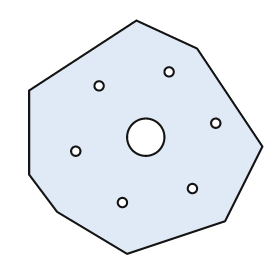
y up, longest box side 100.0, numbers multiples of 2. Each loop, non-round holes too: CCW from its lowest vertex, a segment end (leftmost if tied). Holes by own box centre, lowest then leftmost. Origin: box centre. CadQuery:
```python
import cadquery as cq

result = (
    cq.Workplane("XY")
    .moveTo(-8.0, -50.0)
    .lineTo(34.0, -36.0)
    .lineTo(50.0, -4.0)
    .lineTo(22.0, 38.0)
    .lineTo(-4.0, 50.0)
    .lineTo(-50.0, 20.0)
    .lineTo(-50.0, -16.0)
    .lineTo(-38.0, -32.0)
    .close()
    .moveTo(-10.0, -28.0)
    .circle(2.0)
    .moveTo(20.0, -22.0)
    .circle(2.0)
    .moveTo(-30.0, -6.0)
    .circle(2.0)
    .moveTo(0.0, 0.0)
    .circle(8.0)
    .moveTo(30.0, 6.0)
    .circle(2.0)
    .moveTo(-20.0, 22.0)
    .circle(2.0)
    .moveTo(10.0, 28.0)
    .circle(2.0)
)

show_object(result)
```